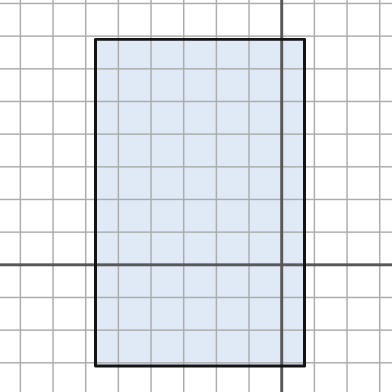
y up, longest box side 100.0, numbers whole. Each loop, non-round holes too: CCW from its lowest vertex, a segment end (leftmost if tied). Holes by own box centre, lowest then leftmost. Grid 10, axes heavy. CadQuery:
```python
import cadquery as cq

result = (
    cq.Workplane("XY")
    .moveTo(-57.0, -31.0)
    .lineTo(7.0, -31.0)
    .lineTo(7.0, 69.0)
    .lineTo(-57.0, 69.0)
    .close()
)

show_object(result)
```